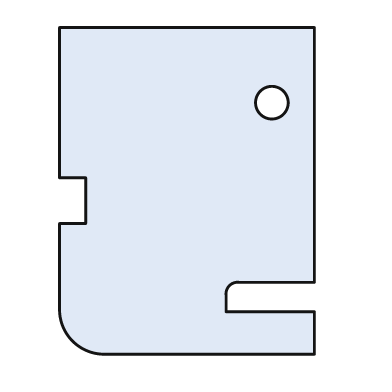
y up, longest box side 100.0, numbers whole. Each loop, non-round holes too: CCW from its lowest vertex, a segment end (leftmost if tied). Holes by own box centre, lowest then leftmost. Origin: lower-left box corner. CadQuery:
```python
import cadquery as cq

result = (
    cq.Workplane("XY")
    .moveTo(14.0, 0.0)
    .lineTo(78.0, 0.0)
    .lineTo(78.0, 13.0)
    .lineTo(51.0, 13.0)
    .lineTo(51.0, 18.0)
    .threePointArc((52.0, 21.0), (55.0, 22.0))
    .lineTo(78.0, 22.0)
    .lineTo(78.0, 100.0)
    .lineTo(0.0, 100.0)
    .lineTo(0.0, 54.0)
    .lineTo(8.0, 54.0)
    .lineTo(8.0, 40.0)
    .lineTo(0.0, 40.0)
    .lineTo(0.0, 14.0)
    .threePointArc((4.0, 4.0), (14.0, 0.0))
    .close()
    .moveTo(65.0, 77.0)
    .circle(5.0)
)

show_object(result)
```